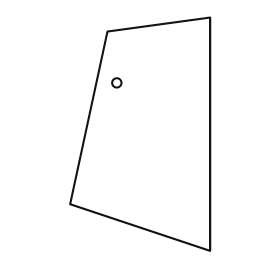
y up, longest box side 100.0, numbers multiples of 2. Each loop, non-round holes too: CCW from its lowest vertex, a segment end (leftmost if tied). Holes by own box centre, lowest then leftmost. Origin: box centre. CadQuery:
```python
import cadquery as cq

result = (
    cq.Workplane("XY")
    .moveTo(30.0, -50.0)
    .lineTo(30.0, 50.0)
    .lineTo(-14.0, 44.0)
    .lineTo(-30.0, -30.0)
    .close()
    .moveTo(-10.0, 22.0)
    .circle(2.0)
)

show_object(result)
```